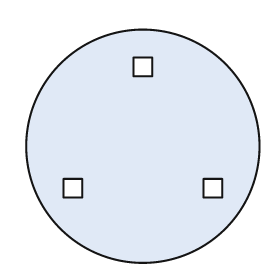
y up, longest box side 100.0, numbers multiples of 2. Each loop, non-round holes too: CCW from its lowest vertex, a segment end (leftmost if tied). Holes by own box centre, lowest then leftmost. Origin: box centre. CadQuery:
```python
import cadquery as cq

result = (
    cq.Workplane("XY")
    .moveTo(0.0, 0.0)
    .circle(50.0)
    .moveTo(-34.0, -22.0)
    .lineTo(-26.0, -22.0)
    .lineTo(-26.0, -14.0)
    .lineTo(-34.0, -14.0)
    .close()
    .moveTo(26.0, -22.0)
    .lineTo(34.0, -22.0)
    .lineTo(34.0, -14.0)
    .lineTo(26.0, -14.0)
    .close()
    .moveTo(-4.0, 30.0)
    .lineTo(4.0, 30.0)
    .lineTo(4.0, 38.0)
    .lineTo(-4.0, 38.0)
    .close()
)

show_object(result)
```